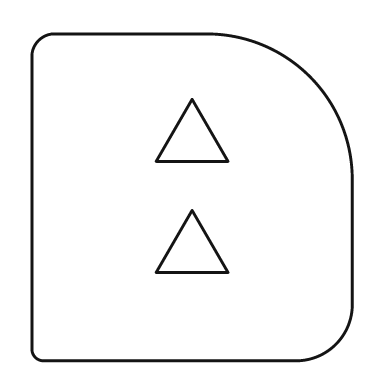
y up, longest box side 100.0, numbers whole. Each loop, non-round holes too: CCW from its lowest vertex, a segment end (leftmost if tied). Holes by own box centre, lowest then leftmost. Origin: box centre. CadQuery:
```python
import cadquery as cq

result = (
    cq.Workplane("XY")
    .moveTo(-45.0, -50.0)
    .lineTo(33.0, -50.0)
    .threePointArc((44.0, -45.0), (49.0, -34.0))
    .lineTo(49.0, 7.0)
    .threePointArc((36.0, 37.0), (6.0, 50.0))
    .lineTo(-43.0, 50.0)
    .threePointArc((-47.0, 48.0), (-49.0, 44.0))
    .lineTo(-49.0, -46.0)
    .threePointArc((-48.0, -49.0), (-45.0, -50.0))
    .close()
    .moveTo(-11.0, -23.0)
    .lineTo(11.0, -23.0)
    .lineTo(0.0, -4.0)
    .close()
    .moveTo(-11.0, 11.0)
    .lineTo(11.0, 11.0)
    .lineTo(0.0, 30.0)
    .close()
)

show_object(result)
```